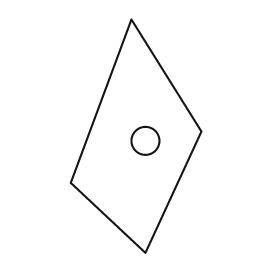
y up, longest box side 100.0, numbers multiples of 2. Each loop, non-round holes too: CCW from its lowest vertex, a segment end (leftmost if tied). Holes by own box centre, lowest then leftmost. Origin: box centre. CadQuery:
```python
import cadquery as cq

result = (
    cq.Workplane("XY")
    .moveTo(4.0, -50.0)
    .lineTo(28.0, 2.0)
    .lineTo(-2.0, 50.0)
    .lineTo(-28.0, -20.0)
    .close()
    .moveTo(4.0, -2.0)
    .circle(6.0)
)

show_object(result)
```